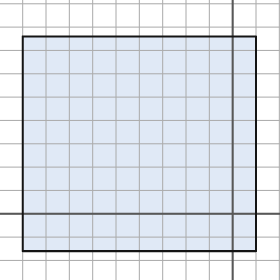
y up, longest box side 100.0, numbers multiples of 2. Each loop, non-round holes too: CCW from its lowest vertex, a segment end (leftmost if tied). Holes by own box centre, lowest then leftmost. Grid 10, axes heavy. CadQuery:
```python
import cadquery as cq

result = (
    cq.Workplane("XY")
    .moveTo(-90.0, -16.0)
    .lineTo(10.0, -16.0)
    .lineTo(10.0, 76.0)
    .lineTo(-90.0, 76.0)
    .close()
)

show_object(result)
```